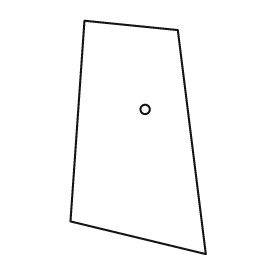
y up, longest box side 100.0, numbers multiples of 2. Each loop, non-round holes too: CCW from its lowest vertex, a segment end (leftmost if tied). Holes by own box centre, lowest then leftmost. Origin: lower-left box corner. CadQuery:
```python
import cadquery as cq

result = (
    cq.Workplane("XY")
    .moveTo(58.0, 0.0)
    .lineTo(46.0, 96.0)
    .lineTo(6.0, 100.0)
    .lineTo(0.0, 14.0)
    .close()
    .moveTo(32.0, 62.0)
    .circle(2.0)
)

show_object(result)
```